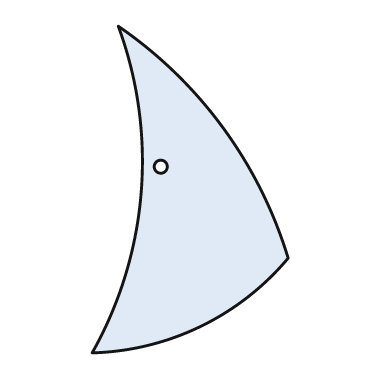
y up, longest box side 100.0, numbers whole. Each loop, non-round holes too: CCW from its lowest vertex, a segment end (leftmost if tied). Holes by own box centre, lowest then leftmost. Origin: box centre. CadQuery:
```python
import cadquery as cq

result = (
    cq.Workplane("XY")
    .moveTo(-30.0, -50.0)
    .threePointArc((3.0, -42.0), (30.0, -21.0))
    .threePointArc((10.0, 19.0), (-22.0, 50.0))
    .threePointArc((-15.0, -1.0), (-30.0, -50.0))
    .close()
    .moveTo(-9.0, 7.0)
    .circle(2.0)
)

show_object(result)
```